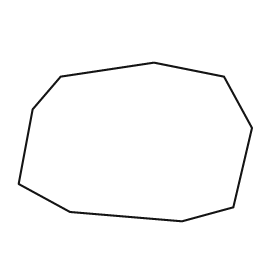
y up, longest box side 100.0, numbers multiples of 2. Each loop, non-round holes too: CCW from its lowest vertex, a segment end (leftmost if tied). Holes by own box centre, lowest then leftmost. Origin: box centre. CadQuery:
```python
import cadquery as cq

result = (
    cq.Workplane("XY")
    .moveTo(20.0, -34.0)
    .lineTo(42.0, -28.0)
    .lineTo(50.0, 6.0)
    .lineTo(38.0, 28.0)
    .lineTo(8.0, 34.0)
    .lineTo(-32.0, 28.0)
    .lineTo(-44.0, 14.0)
    .lineTo(-50.0, -18.0)
    .lineTo(-28.0, -30.0)
    .close()
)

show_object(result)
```